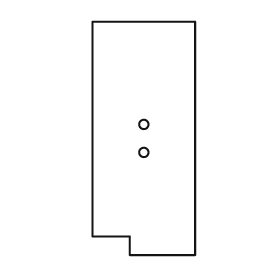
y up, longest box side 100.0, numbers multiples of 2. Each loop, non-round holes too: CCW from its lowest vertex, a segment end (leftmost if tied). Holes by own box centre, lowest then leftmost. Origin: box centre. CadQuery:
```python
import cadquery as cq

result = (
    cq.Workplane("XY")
    .moveTo(-6.0, -50.0)
    .lineTo(22.0, -50.0)
    .lineTo(22.0, 50.0)
    .lineTo(-22.0, 50.0)
    .lineTo(-22.0, -42.0)
    .lineTo(-6.0, -42.0)
    .close()
    .moveTo(0.0, -6.0)
    .circle(2.0)
    .moveTo(0.0, 6.0)
    .circle(2.0)
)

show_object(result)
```